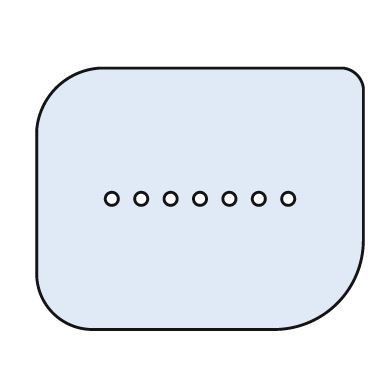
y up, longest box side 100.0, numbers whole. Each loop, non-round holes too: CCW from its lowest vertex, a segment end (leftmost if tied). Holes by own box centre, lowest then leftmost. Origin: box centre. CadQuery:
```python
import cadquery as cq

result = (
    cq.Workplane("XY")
    .moveTo(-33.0, -40.0)
    .lineTo(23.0, -40.0)
    .threePointArc((42.0, -32.0), (50.0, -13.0))
    .lineTo(50.0, 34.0)
    .threePointArc((48.0, 38.0), (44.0, 40.0))
    .lineTo(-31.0, 40.0)
    .threePointArc((-44.0, 34.0), (-50.0, 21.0))
    .lineTo(-50.0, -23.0)
    .threePointArc((-45.0, -35.0), (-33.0, -40.0))
    .close()
    .moveTo(-27.0, 0.0)
    .circle(2.0)
    .moveTo(-18.0, 0.0)
    .circle(2.0)
    .moveTo(-9.0, 0.0)
    .circle(2.0)
    .moveTo(0.0, 0.0)
    .circle(2.0)
    .moveTo(9.0, 0.0)
    .circle(2.0)
    .moveTo(18.0, 0.0)
    .circle(2.0)
    .moveTo(27.0, 0.0)
    .circle(2.0)
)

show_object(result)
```